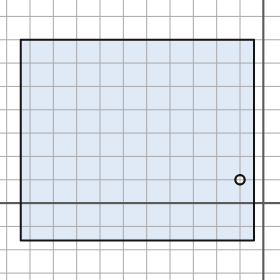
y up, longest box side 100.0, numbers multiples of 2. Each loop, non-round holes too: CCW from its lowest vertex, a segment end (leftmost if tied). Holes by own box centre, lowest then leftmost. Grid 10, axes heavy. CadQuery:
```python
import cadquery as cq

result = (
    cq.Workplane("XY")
    .moveTo(-104.0, -16.0)
    .lineTo(-4.0, -16.0)
    .lineTo(-4.0, 70.0)
    .lineTo(-104.0, 70.0)
    .close()
    .moveTo(-10.0, 10.0)
    .circle(2.0)
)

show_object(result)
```